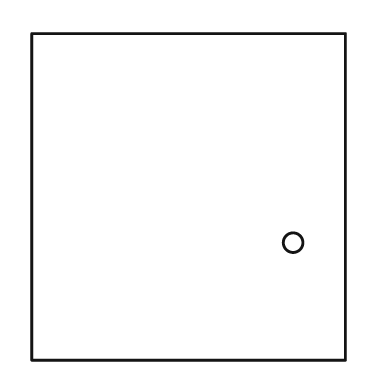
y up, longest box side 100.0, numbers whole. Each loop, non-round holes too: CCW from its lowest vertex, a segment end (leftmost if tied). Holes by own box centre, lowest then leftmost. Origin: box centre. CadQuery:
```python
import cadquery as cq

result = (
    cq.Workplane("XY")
    .moveTo(-48.0, -50.0)
    .lineTo(48.0, -50.0)
    .lineTo(48.0, 50.0)
    .lineTo(-48.0, 50.0)
    .close()
    .moveTo(32.0, -14.0)
    .circle(3.0)
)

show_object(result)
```